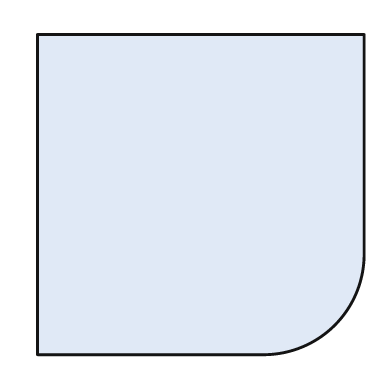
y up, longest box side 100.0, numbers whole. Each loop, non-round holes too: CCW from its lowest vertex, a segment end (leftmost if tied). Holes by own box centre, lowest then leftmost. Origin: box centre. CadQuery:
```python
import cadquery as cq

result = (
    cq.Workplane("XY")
    .moveTo(-50.0, -49.0)
    .lineTo(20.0, -49.0)
    .threePointArc((41.0, -40.0), (50.0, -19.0))
    .lineTo(50.0, 49.0)
    .lineTo(-50.0, 49.0)
    .close()
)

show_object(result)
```